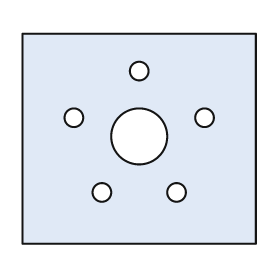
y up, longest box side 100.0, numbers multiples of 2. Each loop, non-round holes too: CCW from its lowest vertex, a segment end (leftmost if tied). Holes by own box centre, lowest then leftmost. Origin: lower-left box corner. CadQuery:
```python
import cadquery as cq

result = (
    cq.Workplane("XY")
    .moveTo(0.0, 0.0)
    .lineTo(100.0, 0.0)
    .lineTo(100.0, 90.0)
    .lineTo(0.0, 90.0)
    .close()
    .moveTo(34.0, 22.0)
    .circle(4.0)
    .moveTo(66.0, 22.0)
    .circle(4.0)
    .moveTo(50.0, 46.0)
    .circle(12.0)
    .moveTo(22.0, 54.0)
    .circle(4.0)
    .moveTo(78.0, 54.0)
    .circle(4.0)
    .moveTo(50.0, 74.0)
    .circle(4.0)
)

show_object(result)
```